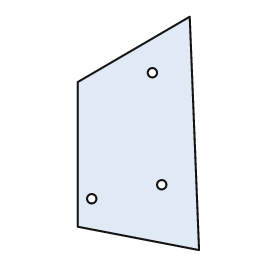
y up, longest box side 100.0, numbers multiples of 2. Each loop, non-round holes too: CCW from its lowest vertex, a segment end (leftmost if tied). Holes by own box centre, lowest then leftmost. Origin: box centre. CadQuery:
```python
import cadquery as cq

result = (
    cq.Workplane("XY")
    .moveTo(26.0, -50.0)
    .lineTo(22.0, 50.0)
    .lineTo(-26.0, 22.0)
    .lineTo(-26.0, -40.0)
    .close()
    .moveTo(-20.0, -28.0)
    .circle(2.0)
    .moveTo(10.0, -22.0)
    .circle(2.0)
    .moveTo(6.0, 26.0)
    .circle(2.0)
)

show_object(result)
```